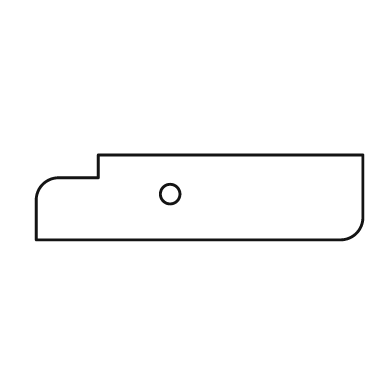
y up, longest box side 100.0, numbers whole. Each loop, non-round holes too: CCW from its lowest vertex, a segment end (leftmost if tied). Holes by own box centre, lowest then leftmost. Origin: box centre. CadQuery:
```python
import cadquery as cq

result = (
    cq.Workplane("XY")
    .moveTo(-50.0, -13.0)
    .lineTo(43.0, -13.0)
    .threePointArc((48.0, -11.0), (50.0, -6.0))
    .lineTo(50.0, 13.0)
    .lineTo(-31.0, 13.0)
    .lineTo(-31.0, 6.0)
    .lineTo(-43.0, 6.0)
    .threePointArc((-48.0, 4.0), (-50.0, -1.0))
    .close()
    .moveTo(-9.0, 1.0)
    .circle(3.0)
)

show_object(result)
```